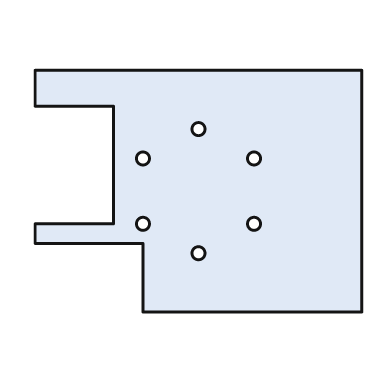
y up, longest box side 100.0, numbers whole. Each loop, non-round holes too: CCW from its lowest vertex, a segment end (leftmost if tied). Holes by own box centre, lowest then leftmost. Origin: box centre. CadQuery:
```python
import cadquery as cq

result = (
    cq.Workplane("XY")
    .moveTo(-17.0, -37.0)
    .lineTo(50.0, -37.0)
    .lineTo(50.0, 37.0)
    .lineTo(-50.0, 37.0)
    .lineTo(-50.0, 26.0)
    .lineTo(-26.0, 26.0)
    .lineTo(-26.0, -10.0)
    .lineTo(-50.0, -10.0)
    .lineTo(-50.0, -16.0)
    .lineTo(-17.0, -16.0)
    .close()
    .moveTo(0.0, -19.0)
    .circle(2.0)
    .moveTo(-17.0, -10.0)
    .circle(2.0)
    .moveTo(17.0, -10.0)
    .circle(2.0)
    .moveTo(-17.0, 10.0)
    .circle(2.0)
    .moveTo(17.0, 10.0)
    .circle(2.0)
    .moveTo(0.0, 19.0)
    .circle(2.0)
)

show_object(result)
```